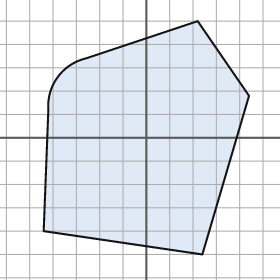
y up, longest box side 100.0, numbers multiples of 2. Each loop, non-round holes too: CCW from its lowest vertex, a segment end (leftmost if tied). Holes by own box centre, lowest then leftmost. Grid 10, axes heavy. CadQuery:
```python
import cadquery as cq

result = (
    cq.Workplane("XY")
    .moveTo(24.0, -50.0)
    .lineTo(44.0, 18.0)
    .lineTo(22.0, 50.0)
    .lineTo(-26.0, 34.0)
    .threePointArc((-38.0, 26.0), (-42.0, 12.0))
    .lineTo(-44.0, -40.0)
    .close()
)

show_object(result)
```